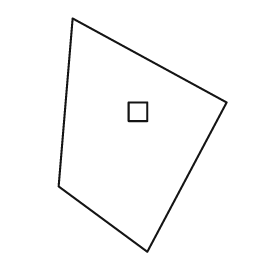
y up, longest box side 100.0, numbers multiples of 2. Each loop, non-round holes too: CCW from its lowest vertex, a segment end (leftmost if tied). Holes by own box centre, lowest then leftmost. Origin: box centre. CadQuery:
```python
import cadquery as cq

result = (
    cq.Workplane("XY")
    .moveTo(2.0, -50.0)
    .lineTo(36.0, 14.0)
    .lineTo(-30.0, 50.0)
    .lineTo(-36.0, -22.0)
    .close()
    .moveTo(-6.0, 6.0)
    .lineTo(2.0, 6.0)
    .lineTo(2.0, 14.0)
    .lineTo(-6.0, 14.0)
    .close()
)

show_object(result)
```